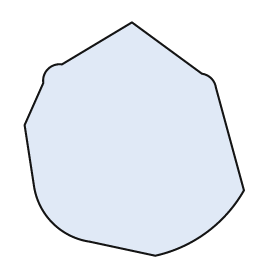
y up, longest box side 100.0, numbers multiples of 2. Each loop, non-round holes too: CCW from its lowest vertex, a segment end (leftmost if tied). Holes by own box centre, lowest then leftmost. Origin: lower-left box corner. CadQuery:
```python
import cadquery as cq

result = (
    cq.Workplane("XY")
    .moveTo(56.0, 0.0)
    .threePointArc((78.0, 10.0), (94.0, 28.0))
    .lineTo(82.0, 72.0)
    .threePointArc((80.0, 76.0), (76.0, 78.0))
    .lineTo(46.0, 100.0)
    .lineTo(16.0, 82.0)
    .threePointArc((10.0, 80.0), (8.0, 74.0))
    .lineTo(0.0, 56.0)
    .lineTo(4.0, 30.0)
    .threePointArc((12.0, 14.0), (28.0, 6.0))
    .close()
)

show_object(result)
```